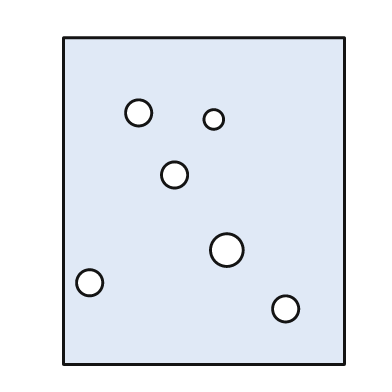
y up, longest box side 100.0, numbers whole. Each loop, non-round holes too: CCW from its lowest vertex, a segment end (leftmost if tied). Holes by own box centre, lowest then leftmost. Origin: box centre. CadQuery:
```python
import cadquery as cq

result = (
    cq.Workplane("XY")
    .moveTo(-43.0, -50.0)
    .lineTo(43.0, -50.0)
    .lineTo(43.0, 50.0)
    .lineTo(-43.0, 50.0)
    .close()
    .moveTo(25.0, -33.0)
    .circle(4.0)
    .moveTo(-35.0, -25.0)
    .circle(4.0)
    .moveTo(7.0, -15.0)
    .circle(5.0)
    .moveTo(-9.0, 8.0)
    .circle(4.0)
    .moveTo(3.0, 25.0)
    .circle(3.0)
    .moveTo(-20.0, 27.0)
    .circle(4.0)
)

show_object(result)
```